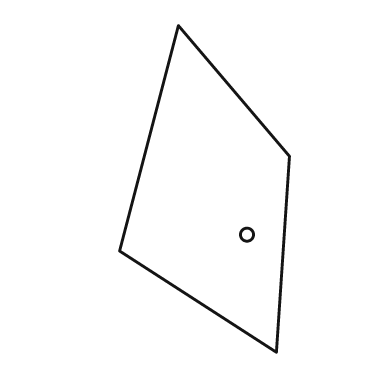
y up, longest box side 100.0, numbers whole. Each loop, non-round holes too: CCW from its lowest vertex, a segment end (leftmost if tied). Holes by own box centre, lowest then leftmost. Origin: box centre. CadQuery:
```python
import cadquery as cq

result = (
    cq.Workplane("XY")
    .moveTo(22.0, -50.0)
    .lineTo(26.0, 10.0)
    .lineTo(-8.0, 50.0)
    .lineTo(-26.0, -19.0)
    .close()
    .moveTo(13.0, -14.0)
    .circle(2.0)
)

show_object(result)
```